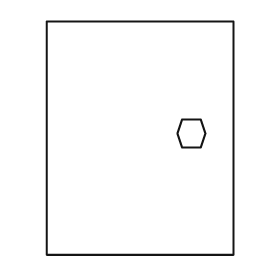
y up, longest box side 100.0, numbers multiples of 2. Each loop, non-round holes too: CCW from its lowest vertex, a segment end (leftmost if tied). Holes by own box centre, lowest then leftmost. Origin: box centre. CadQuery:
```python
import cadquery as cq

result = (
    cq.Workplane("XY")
    .moveTo(-40.0, -50.0)
    .lineTo(40.0, -50.0)
    .lineTo(40.0, 50.0)
    .lineTo(-40.0, 50.0)
    .close()
    .moveTo(18.0, -4.0)
    .lineTo(26.0, -4.0)
    .lineTo(28.0, 2.0)
    .lineTo(26.0, 8.0)
    .lineTo(18.0, 8.0)
    .lineTo(16.0, 2.0)
    .close()
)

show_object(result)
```